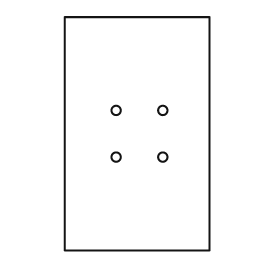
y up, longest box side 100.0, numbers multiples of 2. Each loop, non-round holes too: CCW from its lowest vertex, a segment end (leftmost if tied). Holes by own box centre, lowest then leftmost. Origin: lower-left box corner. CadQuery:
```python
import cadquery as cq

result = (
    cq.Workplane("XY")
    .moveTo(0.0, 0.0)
    .lineTo(62.0, 0.0)
    .lineTo(62.0, 100.0)
    .lineTo(0.0, 100.0)
    .close()
    .moveTo(22.0, 40.0)
    .circle(2.0)
    .moveTo(42.0, 40.0)
    .circle(2.0)
    .moveTo(22.0, 60.0)
    .circle(2.0)
    .moveTo(42.0, 60.0)
    .circle(2.0)
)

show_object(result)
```